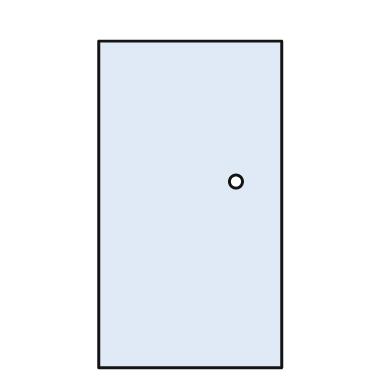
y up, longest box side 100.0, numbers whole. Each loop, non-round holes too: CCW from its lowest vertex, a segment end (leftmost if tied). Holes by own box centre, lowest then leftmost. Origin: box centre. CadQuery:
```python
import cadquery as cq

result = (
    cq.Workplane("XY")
    .moveTo(-28.0, -50.0)
    .lineTo(28.0, -50.0)
    .lineTo(28.0, 50.0)
    .lineTo(-28.0, 50.0)
    .close()
    .moveTo(14.0, 7.0)
    .circle(2.0)
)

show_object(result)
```